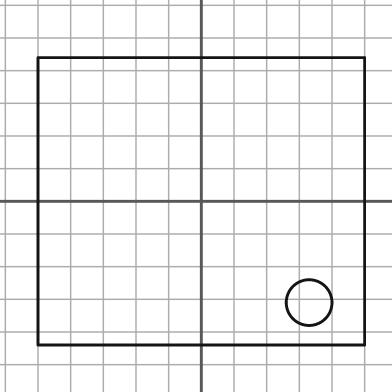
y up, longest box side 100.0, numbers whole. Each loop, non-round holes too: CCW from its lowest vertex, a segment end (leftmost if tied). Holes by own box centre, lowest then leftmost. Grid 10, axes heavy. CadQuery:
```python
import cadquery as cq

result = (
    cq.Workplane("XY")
    .moveTo(-50.0, -44.0)
    .lineTo(50.0, -44.0)
    .lineTo(50.0, 44.0)
    .lineTo(-50.0, 44.0)
    .close()
    .moveTo(33.0, -31.0)
    .circle(7.0)
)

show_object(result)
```